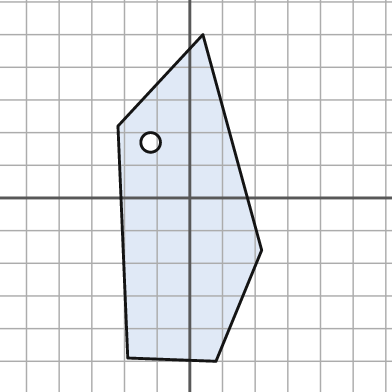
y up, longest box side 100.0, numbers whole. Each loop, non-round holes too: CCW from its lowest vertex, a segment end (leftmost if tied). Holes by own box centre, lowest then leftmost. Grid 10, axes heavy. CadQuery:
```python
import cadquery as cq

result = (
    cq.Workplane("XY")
    .moveTo(8.0, -50.0)
    .lineTo(22.0, -16.0)
    .lineTo(4.0, 50.0)
    .lineTo(-22.0, 22.0)
    .lineTo(-19.0, -49.0)
    .close()
    .moveTo(-12.0, 17.0)
    .circle(3.0)
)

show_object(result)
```